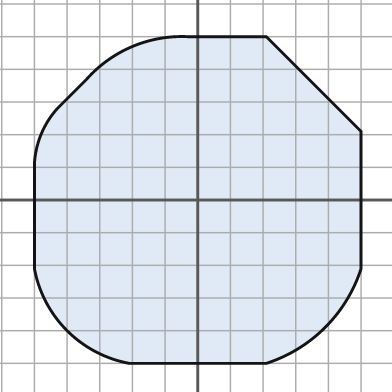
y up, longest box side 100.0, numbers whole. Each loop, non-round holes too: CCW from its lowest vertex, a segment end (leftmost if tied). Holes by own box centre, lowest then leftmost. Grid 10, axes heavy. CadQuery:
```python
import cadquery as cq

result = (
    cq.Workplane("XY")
    .moveTo(-21.0, -50.0)
    .lineTo(21.0, -50.0)
    .threePointArc((39.0, -39.0), (50.0, -21.0))
    .lineTo(50.0, 21.0)
    .lineTo(21.0, 50.0)
    .lineTo(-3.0, 50.0)
    .threePointArc((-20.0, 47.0), (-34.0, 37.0))
    .lineTo(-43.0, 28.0)
    .threePointArc((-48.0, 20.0), (-50.0, 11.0))
    .lineTo(-50.0, -21.0)
    .threePointArc((-40.0, -40.0), (-21.0, -50.0))
    .close()
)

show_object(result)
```